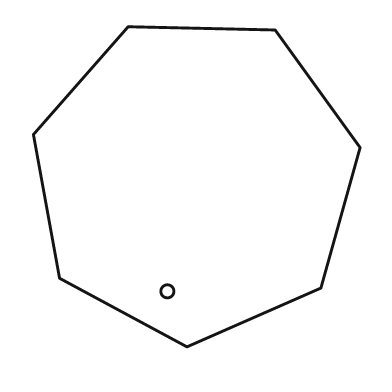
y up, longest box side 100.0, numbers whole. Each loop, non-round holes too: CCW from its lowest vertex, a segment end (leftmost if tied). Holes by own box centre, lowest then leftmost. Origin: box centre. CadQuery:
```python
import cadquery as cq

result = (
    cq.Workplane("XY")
    .moveTo(-3.0, -49.0)
    .lineTo(38.0, -31.0)
    .lineTo(50.0, 12.0)
    .lineTo(24.0, 48.0)
    .lineTo(-21.0, 49.0)
    .lineTo(-50.0, 16.0)
    .lineTo(-42.0, -28.0)
    .close()
    .moveTo(-9.0, -32.0)
    .circle(2.0)
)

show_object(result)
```